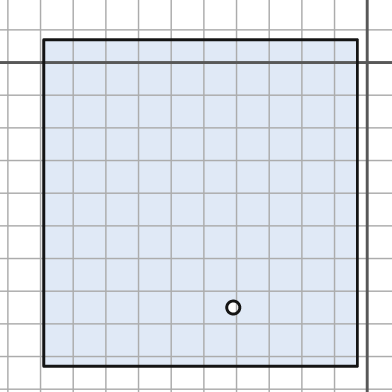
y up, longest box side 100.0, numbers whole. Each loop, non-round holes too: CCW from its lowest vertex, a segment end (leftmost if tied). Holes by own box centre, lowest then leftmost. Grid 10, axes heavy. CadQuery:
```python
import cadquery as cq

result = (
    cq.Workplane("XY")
    .moveTo(-99.0, -93.0)
    .lineTo(-3.0, -93.0)
    .lineTo(-3.0, 7.0)
    .lineTo(-99.0, 7.0)
    .close()
    .moveTo(-41.0, -75.0)
    .circle(2.0)
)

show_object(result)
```